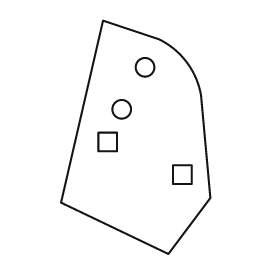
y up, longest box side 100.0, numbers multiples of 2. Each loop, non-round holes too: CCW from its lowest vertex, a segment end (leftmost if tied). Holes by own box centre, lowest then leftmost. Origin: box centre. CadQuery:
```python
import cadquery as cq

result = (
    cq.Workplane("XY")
    .moveTo(14.0, -50.0)
    .lineTo(32.0, -26.0)
    .lineTo(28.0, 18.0)
    .threePointArc((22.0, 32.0), (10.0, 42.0))
    .lineTo(-14.0, 50.0)
    .lineTo(-32.0, -28.0)
    .close()
    .moveTo(16.0, -20.0)
    .lineTo(24.0, -20.0)
    .lineTo(24.0, -12.0)
    .lineTo(16.0, -12.0)
    .close()
    .moveTo(-16.0, -6.0)
    .lineTo(-8.0, -6.0)
    .lineTo(-8.0, 2.0)
    .lineTo(-16.0, 2.0)
    .close()
    .moveTo(-6.0, 12.0)
    .circle(4.0)
    .moveTo(4.0, 30.0)
    .circle(4.0)
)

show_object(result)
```